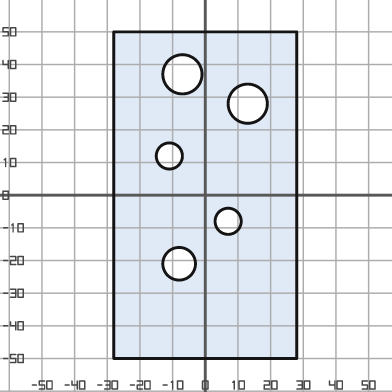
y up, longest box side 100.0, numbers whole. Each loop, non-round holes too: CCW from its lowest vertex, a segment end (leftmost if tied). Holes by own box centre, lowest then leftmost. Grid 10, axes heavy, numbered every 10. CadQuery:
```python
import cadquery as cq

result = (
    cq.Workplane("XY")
    .moveTo(-28.0, -50.0)
    .lineTo(28.0, -50.0)
    .lineTo(28.0, 50.0)
    .lineTo(-28.0, 50.0)
    .close()
    .moveTo(-8.0, -21.0)
    .circle(5.0)
    .moveTo(7.0, -8.0)
    .circle(4.0)
    .moveTo(-11.0, 12.0)
    .circle(4.0)
    .moveTo(13.0, 28.0)
    .circle(6.0)
    .moveTo(-7.0, 37.0)
    .circle(6.0)
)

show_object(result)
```